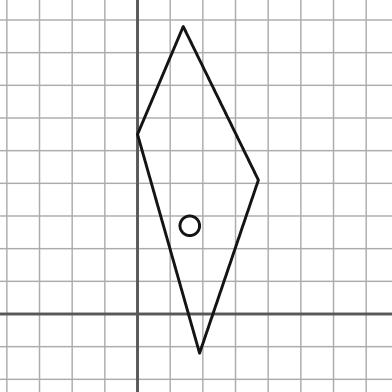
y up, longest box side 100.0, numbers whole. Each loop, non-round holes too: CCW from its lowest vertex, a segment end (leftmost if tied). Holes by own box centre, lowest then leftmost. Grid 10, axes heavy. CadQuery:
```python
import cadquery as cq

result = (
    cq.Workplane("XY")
    .moveTo(19.0, -12.0)
    .lineTo(37.0, 41.0)
    .lineTo(14.0, 88.0)
    .lineTo(0.0, 55.0)
    .close()
    .moveTo(16.0, 27.0)
    .circle(3.0)
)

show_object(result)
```